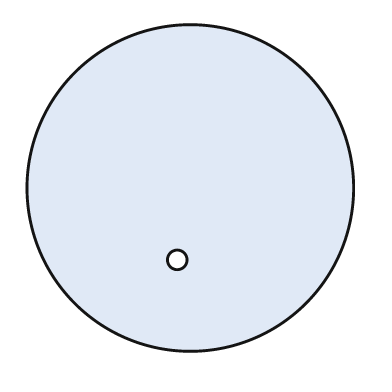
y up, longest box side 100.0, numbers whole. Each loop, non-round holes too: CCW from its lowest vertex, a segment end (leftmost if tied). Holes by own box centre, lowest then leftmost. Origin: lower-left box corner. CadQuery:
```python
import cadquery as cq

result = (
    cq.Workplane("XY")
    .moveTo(50.0, 50.0)
    .circle(50.0)
    .moveTo(46.0, 28.0)
    .circle(3.0)
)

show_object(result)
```